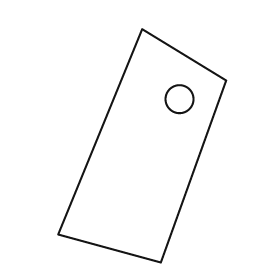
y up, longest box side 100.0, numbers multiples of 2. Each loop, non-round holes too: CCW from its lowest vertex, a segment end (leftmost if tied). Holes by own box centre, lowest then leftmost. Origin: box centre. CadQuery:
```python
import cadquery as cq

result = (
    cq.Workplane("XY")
    .moveTo(8.0, -50.0)
    .lineTo(36.0, 28.0)
    .lineTo(0.0, 50.0)
    .lineTo(-36.0, -38.0)
    .close()
    .moveTo(16.0, 20.0)
    .circle(6.0)
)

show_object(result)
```